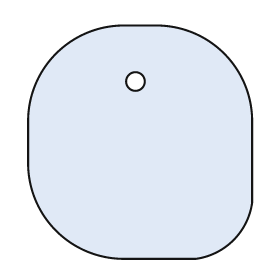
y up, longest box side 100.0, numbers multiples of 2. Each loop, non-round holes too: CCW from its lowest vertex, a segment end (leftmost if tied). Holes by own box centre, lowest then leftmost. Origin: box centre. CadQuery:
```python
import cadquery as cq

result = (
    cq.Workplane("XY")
    .moveTo(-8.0, -50.0)
    .lineTo(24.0, -50.0)
    .threePointArc((40.0, -42.0), (48.0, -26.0))
    .lineTo(48.0, 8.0)
    .threePointArc((36.0, 38.0), (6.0, 50.0))
    .lineTo(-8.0, 50.0)
    .threePointArc((-36.0, 38.0), (-48.0, 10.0))
    .lineTo(-48.0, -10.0)
    .threePointArc((-36.0, -38.0), (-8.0, -50.0))
    .close()
    .moveTo(-2.0, 26.0)
    .circle(4.0)
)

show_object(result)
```